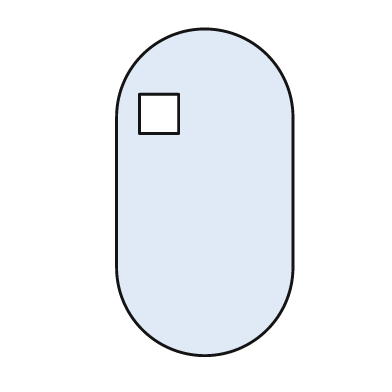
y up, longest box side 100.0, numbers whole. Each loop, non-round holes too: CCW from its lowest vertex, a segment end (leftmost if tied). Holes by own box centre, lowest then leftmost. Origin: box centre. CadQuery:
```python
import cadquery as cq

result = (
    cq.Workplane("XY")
    .moveTo(-27.0, -23.0)
    .threePointArc((0.0, -50.0), (27.0, -23.0))
    .lineTo(27.0, 23.0)
    .threePointArc((0.0, 50.0), (-27.0, 23.0))
    .close()
    .moveTo(-20.0, 18.0)
    .lineTo(-8.0, 18.0)
    .lineTo(-8.0, 30.0)
    .lineTo(-20.0, 30.0)
    .close()
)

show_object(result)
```